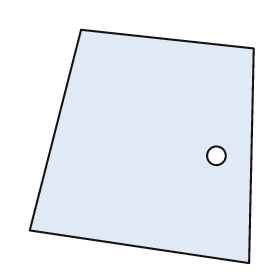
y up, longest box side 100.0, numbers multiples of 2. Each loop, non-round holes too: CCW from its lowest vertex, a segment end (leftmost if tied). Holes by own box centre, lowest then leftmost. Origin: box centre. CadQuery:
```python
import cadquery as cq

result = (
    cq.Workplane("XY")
    .moveTo(46.0, -50.0)
    .lineTo(48.0, 42.0)
    .lineTo(-26.0, 50.0)
    .lineTo(-48.0, -36.0)
    .close()
    .moveTo(32.0, -4.0)
    .circle(4.0)
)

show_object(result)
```